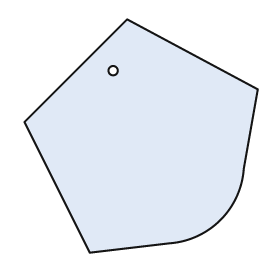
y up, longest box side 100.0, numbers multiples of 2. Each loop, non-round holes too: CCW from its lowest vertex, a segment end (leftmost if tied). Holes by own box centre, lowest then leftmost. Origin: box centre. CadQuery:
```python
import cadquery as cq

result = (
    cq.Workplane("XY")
    .moveTo(-22.0, -50.0)
    .lineTo(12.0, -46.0)
    .threePointArc((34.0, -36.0), (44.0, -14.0))
    .lineTo(50.0, 20.0)
    .lineTo(-6.0, 50.0)
    .lineTo(-50.0, 6.0)
    .close()
    .moveTo(-12.0, 28.0)
    .circle(2.0)
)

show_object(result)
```